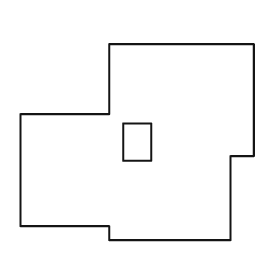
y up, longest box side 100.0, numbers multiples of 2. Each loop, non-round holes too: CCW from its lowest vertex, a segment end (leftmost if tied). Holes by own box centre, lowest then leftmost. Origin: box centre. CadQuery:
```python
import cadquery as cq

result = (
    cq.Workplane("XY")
    .moveTo(-12.0, -42.0)
    .lineTo(40.0, -42.0)
    .lineTo(40.0, -6.0)
    .lineTo(50.0, -6.0)
    .lineTo(50.0, 42.0)
    .lineTo(-12.0, 42.0)
    .lineTo(-12.0, 12.0)
    .lineTo(-50.0, 12.0)
    .lineTo(-50.0, -36.0)
    .lineTo(-12.0, -36.0)
    .close()
    .moveTo(-6.0, -8.0)
    .lineTo(6.0, -8.0)
    .lineTo(6.0, 8.0)
    .lineTo(-6.0, 8.0)
    .close()
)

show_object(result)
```